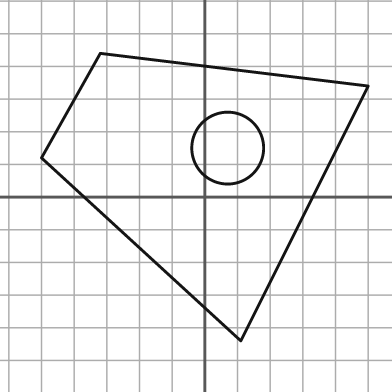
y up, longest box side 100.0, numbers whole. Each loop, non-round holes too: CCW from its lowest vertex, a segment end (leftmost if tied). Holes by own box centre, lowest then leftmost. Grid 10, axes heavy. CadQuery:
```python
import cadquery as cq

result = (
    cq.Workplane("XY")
    .moveTo(11.0, -44.0)
    .lineTo(50.0, 34.0)
    .lineTo(-32.0, 44.0)
    .lineTo(-50.0, 12.0)
    .close()
    .moveTo(7.0, 15.0)
    .circle(11.0)
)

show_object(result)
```